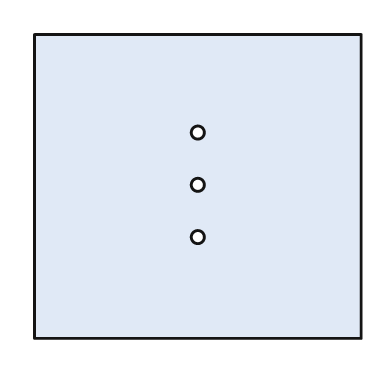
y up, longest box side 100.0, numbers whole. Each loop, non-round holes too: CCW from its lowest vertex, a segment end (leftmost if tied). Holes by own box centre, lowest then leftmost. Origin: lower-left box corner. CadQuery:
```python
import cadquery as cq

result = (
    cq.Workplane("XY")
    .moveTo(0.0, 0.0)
    .lineTo(100.0, 0.0)
    .lineTo(100.0, 93.0)
    .lineTo(0.0, 93.0)
    .close()
    .moveTo(50.0, 31.0)
    .circle(2.0)
    .moveTo(50.0, 47.0)
    .circle(2.0)
    .moveTo(50.0, 63.0)
    .circle(2.0)
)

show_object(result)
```